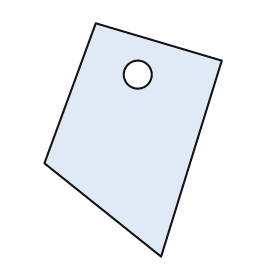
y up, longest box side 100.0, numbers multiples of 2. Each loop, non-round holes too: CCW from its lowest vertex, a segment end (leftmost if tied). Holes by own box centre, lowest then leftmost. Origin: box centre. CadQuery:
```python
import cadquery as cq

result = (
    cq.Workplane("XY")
    .moveTo(12.0, -50.0)
    .lineTo(38.0, 34.0)
    .lineTo(-16.0, 50.0)
    .lineTo(-38.0, -10.0)
    .close()
    .moveTo(2.0, 28.0)
    .circle(6.0)
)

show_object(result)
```